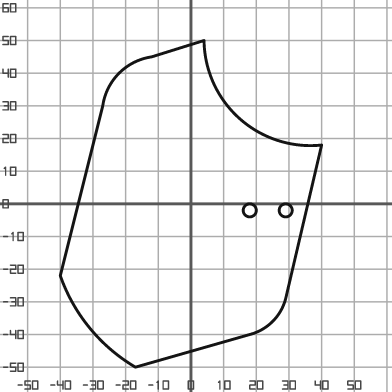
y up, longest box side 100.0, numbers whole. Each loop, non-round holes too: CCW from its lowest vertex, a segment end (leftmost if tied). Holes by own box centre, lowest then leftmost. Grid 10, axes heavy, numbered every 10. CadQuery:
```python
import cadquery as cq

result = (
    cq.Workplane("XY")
    .moveTo(-17.0, -50.0)
    .lineTo(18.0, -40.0)
    .threePointArc((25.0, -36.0), (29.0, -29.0))
    .lineTo(40.0, 18.0)
    .threePointArc((15.0, 26.0), (4.0, 50.0))
    .lineTo(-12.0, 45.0)
    .threePointArc((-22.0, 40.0), (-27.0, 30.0))
    .lineTo(-40.0, -22.0)
    .threePointArc((-31.0, -38.0), (-17.0, -50.0))
    .close()
    .moveTo(18.0, -2.0)
    .circle(2.0)
    .moveTo(29.0, -2.0)
    .circle(2.0)
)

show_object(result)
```